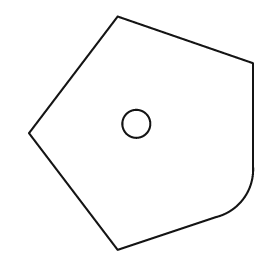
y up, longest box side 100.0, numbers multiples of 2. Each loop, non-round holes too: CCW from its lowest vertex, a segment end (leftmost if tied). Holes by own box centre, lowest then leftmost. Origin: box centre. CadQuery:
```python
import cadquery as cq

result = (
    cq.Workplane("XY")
    .moveTo(-10.0, -50.0)
    .lineTo(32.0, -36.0)
    .threePointArc((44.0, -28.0), (48.0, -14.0))
    .lineTo(48.0, 30.0)
    .lineTo(-10.0, 50.0)
    .lineTo(-48.0, 0.0)
    .close()
    .moveTo(-2.0, 4.0)
    .circle(6.0)
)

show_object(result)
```